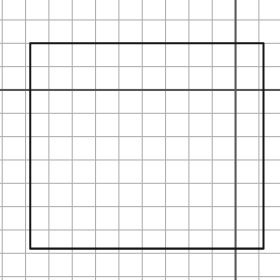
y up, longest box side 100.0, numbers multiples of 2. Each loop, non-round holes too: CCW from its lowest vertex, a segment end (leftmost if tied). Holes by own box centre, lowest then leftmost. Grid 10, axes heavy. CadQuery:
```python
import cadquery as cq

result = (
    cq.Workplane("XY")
    .moveTo(-88.0, -68.0)
    .lineTo(12.0, -68.0)
    .lineTo(12.0, 20.0)
    .lineTo(-88.0, 20.0)
    .close()
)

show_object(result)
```